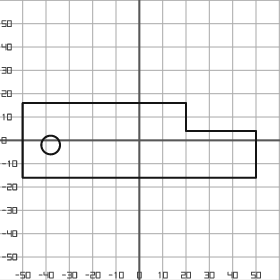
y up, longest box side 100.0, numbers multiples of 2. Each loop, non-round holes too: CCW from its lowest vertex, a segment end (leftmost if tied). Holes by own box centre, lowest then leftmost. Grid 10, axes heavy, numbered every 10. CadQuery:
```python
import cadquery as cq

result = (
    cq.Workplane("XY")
    .moveTo(-50.0, -16.0)
    .lineTo(50.0, -16.0)
    .lineTo(50.0, 4.0)
    .lineTo(20.0, 4.0)
    .lineTo(20.0, 16.0)
    .lineTo(-50.0, 16.0)
    .close()
    .moveTo(-38.0, -2.0)
    .circle(4.0)
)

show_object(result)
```